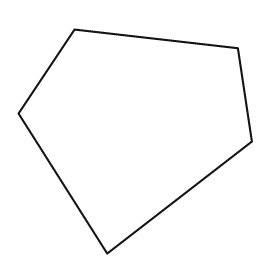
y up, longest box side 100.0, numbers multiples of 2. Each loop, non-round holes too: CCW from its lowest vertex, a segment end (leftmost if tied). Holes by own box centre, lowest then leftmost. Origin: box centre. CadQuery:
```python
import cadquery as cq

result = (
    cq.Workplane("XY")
    .moveTo(-12.0, -48.0)
    .lineTo(50.0, 0.0)
    .lineTo(44.0, 40.0)
    .lineTo(-26.0, 48.0)
    .lineTo(-50.0, 12.0)
    .close()
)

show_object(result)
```